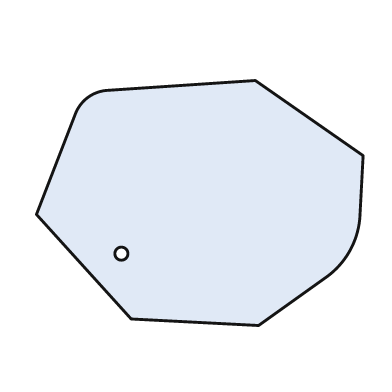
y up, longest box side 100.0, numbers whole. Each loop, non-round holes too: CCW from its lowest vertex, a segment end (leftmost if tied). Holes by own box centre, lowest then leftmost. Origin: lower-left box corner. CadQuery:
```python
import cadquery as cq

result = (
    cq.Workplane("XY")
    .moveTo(68.0, 0.0)
    .lineTo(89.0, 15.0)
    .threePointArc((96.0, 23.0), (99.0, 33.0))
    .lineTo(100.0, 52.0)
    .lineTo(67.0, 75.0)
    .lineTo(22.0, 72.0)
    .threePointArc((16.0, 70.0), (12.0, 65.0))
    .lineTo(0.0, 34.0)
    .lineTo(29.0, 2.0)
    .close()
    .moveTo(26.0, 22.0)
    .circle(2.0)
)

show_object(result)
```